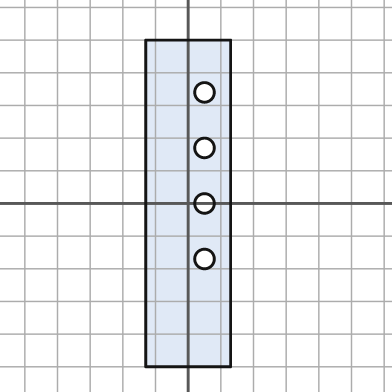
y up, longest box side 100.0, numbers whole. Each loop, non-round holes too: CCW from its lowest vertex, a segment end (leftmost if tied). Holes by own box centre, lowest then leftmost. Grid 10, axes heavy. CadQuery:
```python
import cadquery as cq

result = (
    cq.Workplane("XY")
    .moveTo(-13.0, -50.0)
    .lineTo(13.0, -50.0)
    .lineTo(13.0, 50.0)
    .lineTo(-13.0, 50.0)
    .close()
    .moveTo(5.0, -17.0)
    .circle(3.0)
    .moveTo(5.0, 0.0)
    .circle(3.0)
    .moveTo(5.0, 17.0)
    .circle(3.0)
    .moveTo(5.0, 34.0)
    .circle(3.0)
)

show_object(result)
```